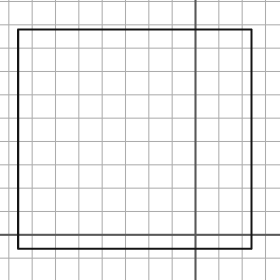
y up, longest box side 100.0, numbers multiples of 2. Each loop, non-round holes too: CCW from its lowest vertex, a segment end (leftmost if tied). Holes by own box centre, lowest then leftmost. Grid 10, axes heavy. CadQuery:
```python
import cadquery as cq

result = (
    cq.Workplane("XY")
    .moveTo(-76.0, -6.0)
    .lineTo(24.0, -6.0)
    .lineTo(24.0, 88.0)
    .lineTo(-76.0, 88.0)
    .close()
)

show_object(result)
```